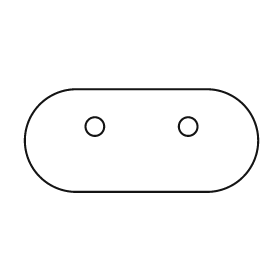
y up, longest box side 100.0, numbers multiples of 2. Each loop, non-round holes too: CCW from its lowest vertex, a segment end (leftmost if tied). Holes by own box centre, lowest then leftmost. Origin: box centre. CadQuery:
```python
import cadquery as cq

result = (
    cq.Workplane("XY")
    .moveTo(-28.0, -22.0)
    .lineTo(28.0, -22.0)
    .threePointArc((50.0, 0.0), (28.0, 22.0))
    .lineTo(-28.0, 22.0)
    .threePointArc((-50.0, 0.0), (-28.0, -22.0))
    .close()
    .moveTo(-20.0, 6.0)
    .circle(4.0)
    .moveTo(20.0, 6.0)
    .circle(4.0)
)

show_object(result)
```